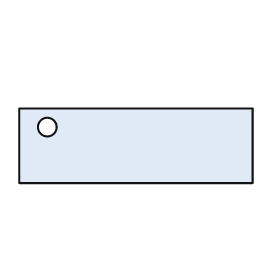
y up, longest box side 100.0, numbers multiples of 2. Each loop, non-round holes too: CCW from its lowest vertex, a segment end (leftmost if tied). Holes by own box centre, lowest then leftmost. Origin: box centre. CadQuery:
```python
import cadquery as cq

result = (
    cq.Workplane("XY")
    .moveTo(-50.0, -16.0)
    .lineTo(50.0, -16.0)
    .lineTo(50.0, 16.0)
    .lineTo(-50.0, 16.0)
    .close()
    .moveTo(-38.0, 8.0)
    .circle(4.0)
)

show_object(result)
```